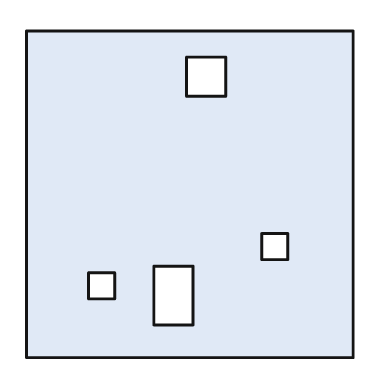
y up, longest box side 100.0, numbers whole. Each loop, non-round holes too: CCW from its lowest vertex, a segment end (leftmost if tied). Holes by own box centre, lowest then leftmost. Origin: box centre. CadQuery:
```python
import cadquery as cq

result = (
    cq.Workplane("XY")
    .moveTo(-50.0, -50.0)
    .lineTo(50.0, -50.0)
    .lineTo(50.0, 50.0)
    .lineTo(-50.0, 50.0)
    .close()
    .moveTo(-11.0, -40.0)
    .lineTo(1.0, -40.0)
    .lineTo(1.0, -22.0)
    .lineTo(-11.0, -22.0)
    .close()
    .moveTo(-31.0, -32.0)
    .lineTo(-23.0, -32.0)
    .lineTo(-23.0, -24.0)
    .lineTo(-31.0, -24.0)
    .close()
    .moveTo(22.0, -20.0)
    .lineTo(30.0, -20.0)
    .lineTo(30.0, -12.0)
    .lineTo(22.0, -12.0)
    .close()
    .moveTo(-1.0, 30.0)
    .lineTo(11.0, 30.0)
    .lineTo(11.0, 42.0)
    .lineTo(-1.0, 42.0)
    .close()
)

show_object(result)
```